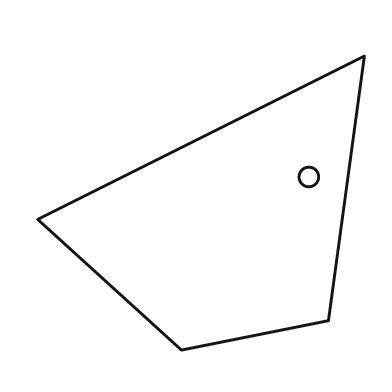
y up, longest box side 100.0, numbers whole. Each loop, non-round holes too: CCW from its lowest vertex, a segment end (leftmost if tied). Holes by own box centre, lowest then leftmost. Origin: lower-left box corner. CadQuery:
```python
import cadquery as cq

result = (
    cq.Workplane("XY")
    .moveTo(44.0, 0.0)
    .lineTo(89.0, 9.0)
    .lineTo(100.0, 90.0)
    .lineTo(0.0, 40.0)
    .close()
    .moveTo(83.0, 53.0)
    .circle(3.0)
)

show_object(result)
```